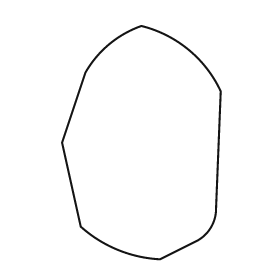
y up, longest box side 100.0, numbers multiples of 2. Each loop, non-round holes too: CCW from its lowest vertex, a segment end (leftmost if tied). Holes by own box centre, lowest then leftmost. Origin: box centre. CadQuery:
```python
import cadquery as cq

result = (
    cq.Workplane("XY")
    .moveTo(8.0, -50.0)
    .lineTo(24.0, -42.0)
    .threePointArc((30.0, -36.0), (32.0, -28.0))
    .lineTo(34.0, 22.0)
    .threePointArc((20.0, 40.0), (0.0, 50.0))
    .threePointArc((-14.0, 42.0), (-24.0, 30.0))
    .lineTo(-34.0, 0.0)
    .lineTo(-26.0, -36.0)
    .threePointArc((-10.0, -46.0), (8.0, -50.0))
    .close()
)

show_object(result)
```